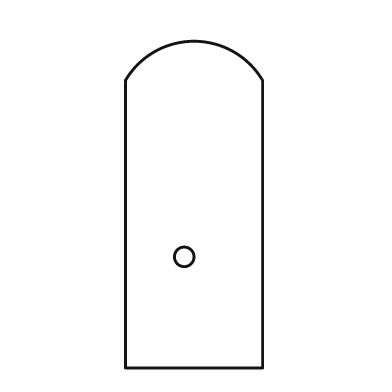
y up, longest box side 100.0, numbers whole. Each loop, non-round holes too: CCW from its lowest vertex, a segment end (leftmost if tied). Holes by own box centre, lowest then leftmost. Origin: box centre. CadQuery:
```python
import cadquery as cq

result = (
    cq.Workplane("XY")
    .moveTo(-21.0, -50.0)
    .lineTo(21.0, -50.0)
    .lineTo(21.0, 38.0)
    .threePointArc((0.0, 50.0), (-21.0, 38.0))
    .close()
    .moveTo(-3.0, -16.0)
    .circle(3.0)
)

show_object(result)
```